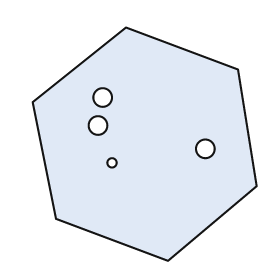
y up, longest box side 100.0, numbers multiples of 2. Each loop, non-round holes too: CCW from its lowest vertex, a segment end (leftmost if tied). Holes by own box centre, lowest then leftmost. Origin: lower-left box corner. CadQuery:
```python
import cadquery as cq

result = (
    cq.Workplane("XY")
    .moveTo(58.0, 0.0)
    .lineTo(96.0, 32.0)
    .lineTo(88.0, 82.0)
    .lineTo(40.0, 100.0)
    .lineTo(0.0, 68.0)
    .lineTo(10.0, 18.0)
    .close()
    .moveTo(34.0, 42.0)
    .circle(2.0)
    .moveTo(74.0, 48.0)
    .circle(4.0)
    .moveTo(28.0, 58.0)
    .circle(4.0)
    .moveTo(30.0, 70.0)
    .circle(4.0)
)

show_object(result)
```